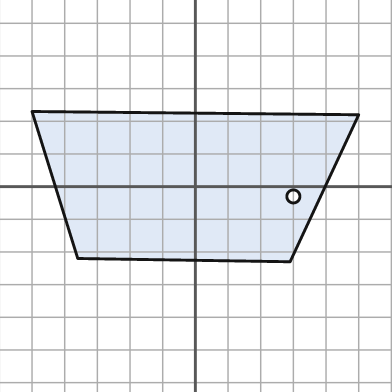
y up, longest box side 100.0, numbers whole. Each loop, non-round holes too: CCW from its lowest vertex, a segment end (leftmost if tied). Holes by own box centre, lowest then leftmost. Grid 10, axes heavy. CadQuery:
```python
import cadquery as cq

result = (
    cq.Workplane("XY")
    .moveTo(29.0, -23.0)
    .lineTo(50.0, 22.0)
    .lineTo(-50.0, 23.0)
    .lineTo(-36.0, -22.0)
    .close()
    .moveTo(30.0, -3.0)
    .circle(2.0)
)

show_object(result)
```